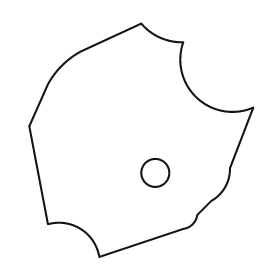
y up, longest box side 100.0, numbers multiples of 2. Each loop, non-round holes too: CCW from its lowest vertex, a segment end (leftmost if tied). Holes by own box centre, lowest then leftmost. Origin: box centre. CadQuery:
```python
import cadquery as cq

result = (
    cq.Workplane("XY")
    .moveTo(-18.0, -50.0)
    .lineTo(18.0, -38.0)
    .threePointArc((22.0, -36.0), (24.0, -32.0))
    .lineTo(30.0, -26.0)
    .threePointArc((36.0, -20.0), (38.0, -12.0))
    .lineTo(48.0, 14.0)
    .threePointArc((24.0, 18.0), (18.0, 42.0))
    .threePointArc((8.0, 44.0), (0.0, 50.0))
    .lineTo(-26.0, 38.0)
    .threePointArc((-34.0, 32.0), (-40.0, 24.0))
    .lineTo(-48.0, 6.0)
    .lineTo(-40.0, -36.0)
    .threePointArc((-26.0, -38.0), (-18.0, -50.0))
    .close()
    .moveTo(6.0, -14.0)
    .circle(6.0)
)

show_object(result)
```